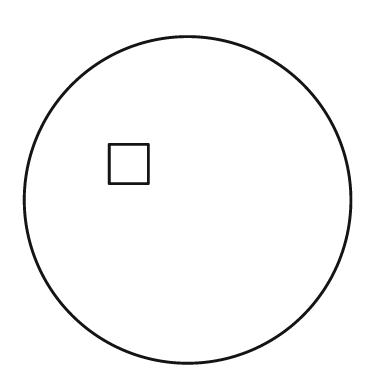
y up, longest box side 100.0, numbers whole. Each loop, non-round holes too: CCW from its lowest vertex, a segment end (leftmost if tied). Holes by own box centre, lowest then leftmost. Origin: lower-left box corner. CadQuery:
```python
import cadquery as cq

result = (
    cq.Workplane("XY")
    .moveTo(50.0, 50.0)
    .circle(50.0)
    .moveTo(26.0, 55.0)
    .lineTo(38.0, 55.0)
    .lineTo(38.0, 67.0)
    .lineTo(26.0, 67.0)
    .close()
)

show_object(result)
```